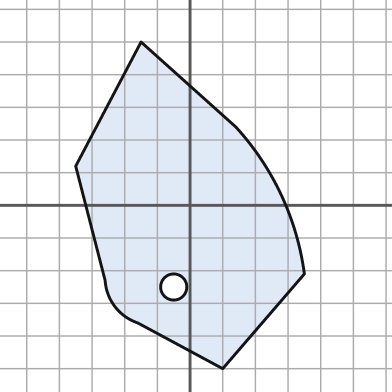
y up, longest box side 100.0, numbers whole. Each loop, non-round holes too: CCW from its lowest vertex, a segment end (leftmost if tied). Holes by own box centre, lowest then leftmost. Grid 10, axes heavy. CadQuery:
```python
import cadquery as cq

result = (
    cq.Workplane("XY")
    .moveTo(10.0, -50.0)
    .lineTo(35.0, -21.0)
    .threePointArc((28.0, 3.0), (14.0, 24.0))
    .lineTo(-15.0, 50.0)
    .lineTo(-35.0, 12.0)
    .lineTo(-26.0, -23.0)
    .threePointArc((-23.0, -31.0), (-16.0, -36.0))
    .close()
    .moveTo(-5.0, -25.0)
    .circle(4.0)
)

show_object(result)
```